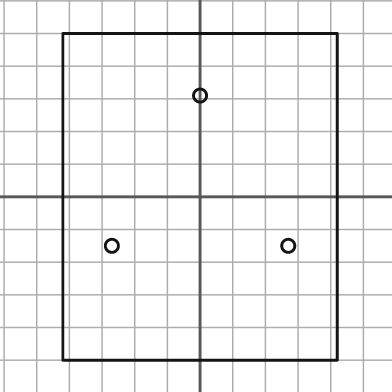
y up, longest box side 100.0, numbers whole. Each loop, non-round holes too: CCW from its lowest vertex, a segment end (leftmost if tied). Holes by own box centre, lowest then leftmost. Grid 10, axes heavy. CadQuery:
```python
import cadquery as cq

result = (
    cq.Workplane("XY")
    .moveTo(-42.0, -50.0)
    .lineTo(42.0, -50.0)
    .lineTo(42.0, 50.0)
    .lineTo(-42.0, 50.0)
    .close()
    .moveTo(-27.0, -15.0)
    .circle(2.0)
    .moveTo(27.0, -15.0)
    .circle(2.0)
    .moveTo(0.0, 31.0)
    .circle(2.0)
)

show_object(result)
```